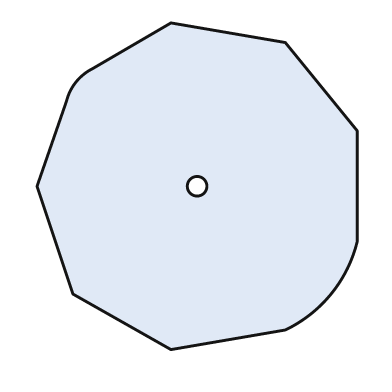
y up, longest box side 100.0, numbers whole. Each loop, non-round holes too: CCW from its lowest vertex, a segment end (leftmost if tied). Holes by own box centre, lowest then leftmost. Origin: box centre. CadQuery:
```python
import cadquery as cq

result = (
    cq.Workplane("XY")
    .moveTo(-8.0, -50.0)
    .lineTo(27.0, -44.0)
    .threePointArc((41.0, -33.0), (49.0, -17.0))
    .lineTo(49.0, 17.0)
    .lineTo(27.0, 44.0)
    .lineTo(-8.0, 50.0)
    .lineTo(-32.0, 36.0)
    .threePointArc((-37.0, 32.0), (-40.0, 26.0))
    .lineTo(-49.0, 0.0)
    .lineTo(-38.0, -33.0)
    .close()
    .moveTo(0.0, 0.0)
    .circle(3.0)
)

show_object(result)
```